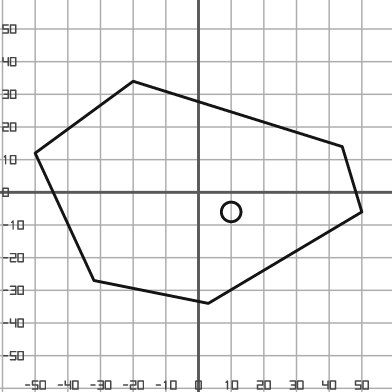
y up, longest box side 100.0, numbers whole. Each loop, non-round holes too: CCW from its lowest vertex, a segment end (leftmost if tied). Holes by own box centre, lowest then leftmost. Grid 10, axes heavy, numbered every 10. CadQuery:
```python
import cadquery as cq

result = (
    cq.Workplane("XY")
    .moveTo(3.0, -34.0)
    .lineTo(50.0, -6.0)
    .lineTo(44.0, 14.0)
    .lineTo(-20.0, 34.0)
    .lineTo(-50.0, 12.0)
    .lineTo(-32.0, -27.0)
    .close()
    .moveTo(10.0, -6.0)
    .circle(3.0)
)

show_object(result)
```